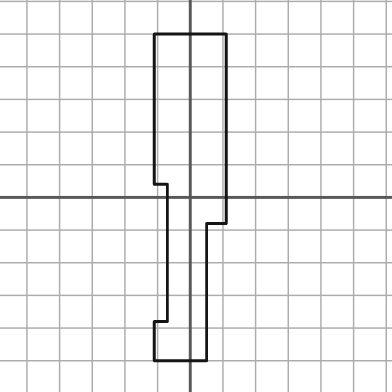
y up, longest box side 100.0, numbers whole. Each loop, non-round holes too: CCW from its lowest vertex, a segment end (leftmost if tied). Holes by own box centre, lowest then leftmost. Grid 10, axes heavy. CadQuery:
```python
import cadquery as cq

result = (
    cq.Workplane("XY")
    .moveTo(-11.0, -50.0)
    .lineTo(5.0, -50.0)
    .lineTo(5.0, -8.0)
    .lineTo(11.0, -8.0)
    .lineTo(11.0, 50.0)
    .lineTo(-11.0, 50.0)
    .lineTo(-11.0, 4.0)
    .lineTo(-7.0, 4.0)
    .lineTo(-7.0, -38.0)
    .lineTo(-11.0, -38.0)
    .close()
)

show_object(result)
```